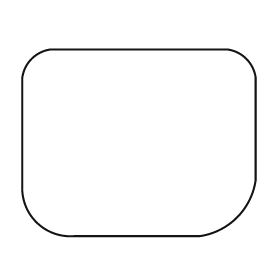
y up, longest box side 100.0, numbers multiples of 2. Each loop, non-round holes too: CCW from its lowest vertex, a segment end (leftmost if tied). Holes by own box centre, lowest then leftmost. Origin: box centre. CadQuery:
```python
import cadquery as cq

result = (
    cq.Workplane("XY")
    .moveTo(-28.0, -40.0)
    .lineTo(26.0, -40.0)
    .threePointArc((42.0, -32.0), (50.0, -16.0))
    .lineTo(50.0, 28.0)
    .threePointArc((46.0, 36.0), (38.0, 40.0))
    .lineTo(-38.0, 40.0)
    .threePointArc((-46.0, 36.0), (-50.0, 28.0))
    .lineTo(-50.0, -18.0)
    .threePointArc((-44.0, -34.0), (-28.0, -40.0))
    .close()
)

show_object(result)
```